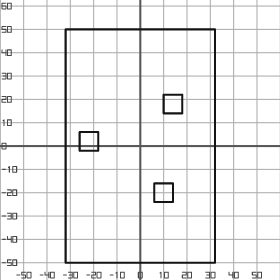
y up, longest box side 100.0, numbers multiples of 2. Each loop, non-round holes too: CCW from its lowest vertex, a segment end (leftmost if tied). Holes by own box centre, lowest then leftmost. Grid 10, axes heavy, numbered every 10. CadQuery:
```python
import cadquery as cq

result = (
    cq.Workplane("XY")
    .moveTo(-32.0, -50.0)
    .lineTo(32.0, -50.0)
    .lineTo(32.0, 50.0)
    .lineTo(-32.0, 50.0)
    .close()
    .moveTo(6.0, -24.0)
    .lineTo(14.0, -24.0)
    .lineTo(14.0, -16.0)
    .lineTo(6.0, -16.0)
    .close()
    .moveTo(-26.0, -2.0)
    .lineTo(-18.0, -2.0)
    .lineTo(-18.0, 6.0)
    .lineTo(-26.0, 6.0)
    .close()
    .moveTo(10.0, 14.0)
    .lineTo(18.0, 14.0)
    .lineTo(18.0, 22.0)
    .lineTo(10.0, 22.0)
    .close()
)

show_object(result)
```